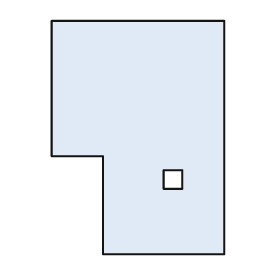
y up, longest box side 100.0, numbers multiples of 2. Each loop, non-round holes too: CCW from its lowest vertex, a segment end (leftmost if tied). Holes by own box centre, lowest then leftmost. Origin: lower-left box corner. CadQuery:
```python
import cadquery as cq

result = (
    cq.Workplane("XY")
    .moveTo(22.0, 0.0)
    .lineTo(74.0, 0.0)
    .lineTo(74.0, 100.0)
    .lineTo(0.0, 100.0)
    .lineTo(0.0, 42.0)
    .lineTo(22.0, 42.0)
    .close()
    .moveTo(48.0, 28.0)
    .lineTo(56.0, 28.0)
    .lineTo(56.0, 36.0)
    .lineTo(48.0, 36.0)
    .close()
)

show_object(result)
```